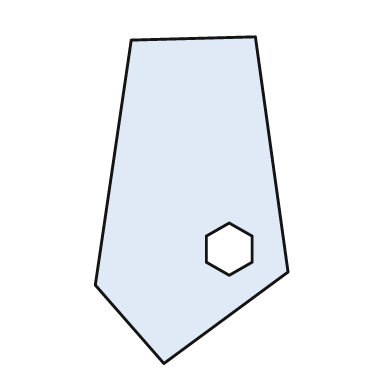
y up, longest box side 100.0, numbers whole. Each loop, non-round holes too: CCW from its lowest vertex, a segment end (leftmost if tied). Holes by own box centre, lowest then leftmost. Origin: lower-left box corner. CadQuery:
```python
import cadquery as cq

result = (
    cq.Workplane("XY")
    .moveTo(21.0, 0.0)
    .lineTo(59.0, 28.0)
    .lineTo(49.0, 100.0)
    .lineTo(11.0, 99.0)
    .lineTo(0.0, 24.0)
    .close()
    .moveTo(41.0, 27.0)
    .lineTo(48.0, 31.0)
    .lineTo(48.0, 39.0)
    .lineTo(41.0, 43.0)
    .lineTo(34.0, 39.0)
    .lineTo(34.0, 31.0)
    .close()
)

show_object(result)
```